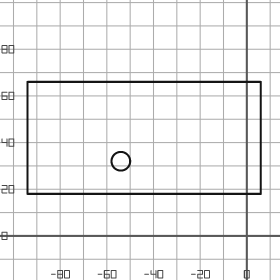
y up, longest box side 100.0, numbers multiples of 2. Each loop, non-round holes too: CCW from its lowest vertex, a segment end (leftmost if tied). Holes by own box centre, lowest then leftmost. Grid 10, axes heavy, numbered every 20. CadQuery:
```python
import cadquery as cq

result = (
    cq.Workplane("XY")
    .moveTo(-94.0, 18.0)
    .lineTo(6.0, 18.0)
    .lineTo(6.0, 66.0)
    .lineTo(-94.0, 66.0)
    .close()
    .moveTo(-54.0, 32.0)
    .circle(4.0)
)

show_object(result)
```